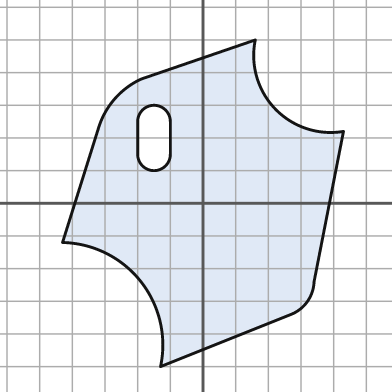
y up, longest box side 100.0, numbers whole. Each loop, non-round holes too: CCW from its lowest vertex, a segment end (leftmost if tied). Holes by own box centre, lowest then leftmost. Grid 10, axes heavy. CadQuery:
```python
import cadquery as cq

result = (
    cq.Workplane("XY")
    .moveTo(-13.0, -50.0)
    .lineTo(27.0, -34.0)
    .threePointArc((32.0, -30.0), (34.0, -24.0))
    .lineTo(43.0, 22.0)
    .threePointArc((22.0, 29.0), (16.0, 50.0))
    .lineTo(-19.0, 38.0)
    .threePointArc((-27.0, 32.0), (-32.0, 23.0))
    .lineTo(-43.0, -12.0)
    .threePointArc((-19.0, -24.0), (-13.0, -50.0))
    .close()
    .moveTo(-20.0, 15.0)
    .threePointArc((-15.0, 10.0), (-10.0, 15.0))
    .lineTo(-10.0, 25.0)
    .threePointArc((-15.0, 30.0), (-20.0, 25.0))
    .close()
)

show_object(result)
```